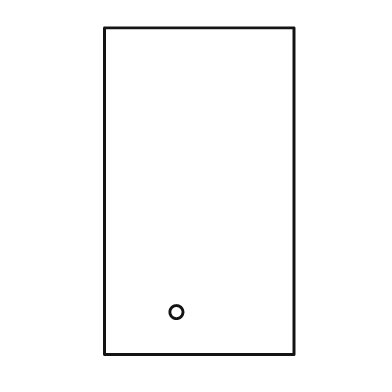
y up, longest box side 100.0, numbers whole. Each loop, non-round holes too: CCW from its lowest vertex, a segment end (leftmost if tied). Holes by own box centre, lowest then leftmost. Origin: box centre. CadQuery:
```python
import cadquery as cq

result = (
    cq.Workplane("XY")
    .moveTo(-29.0, -50.0)
    .lineTo(29.0, -50.0)
    .lineTo(29.0, 50.0)
    .lineTo(-29.0, 50.0)
    .close()
    .moveTo(-7.0, -37.0)
    .circle(2.0)
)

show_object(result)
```